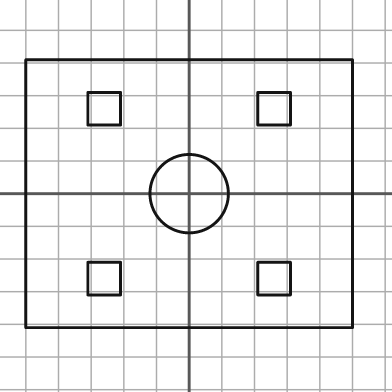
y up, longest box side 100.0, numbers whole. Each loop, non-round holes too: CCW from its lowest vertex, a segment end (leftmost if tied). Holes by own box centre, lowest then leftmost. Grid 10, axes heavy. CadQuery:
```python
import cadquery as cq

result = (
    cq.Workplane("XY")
    .moveTo(-50.0, -41.0)
    .lineTo(50.0, -41.0)
    .lineTo(50.0, 41.0)
    .lineTo(-50.0, 41.0)
    .close()
    .moveTo(-31.0, -31.0)
    .lineTo(-21.0, -31.0)
    .lineTo(-21.0, -21.0)
    .lineTo(-31.0, -21.0)
    .close()
    .moveTo(21.0, -31.0)
    .lineTo(31.0, -31.0)
    .lineTo(31.0, -21.0)
    .lineTo(21.0, -21.0)
    .close()
    .moveTo(0.0, 0.0)
    .circle(12.0)
    .moveTo(-31.0, 21.0)
    .lineTo(-21.0, 21.0)
    .lineTo(-21.0, 31.0)
    .lineTo(-31.0, 31.0)
    .close()
    .moveTo(21.0, 21.0)
    .lineTo(31.0, 21.0)
    .lineTo(31.0, 31.0)
    .lineTo(21.0, 31.0)
    .close()
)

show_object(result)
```